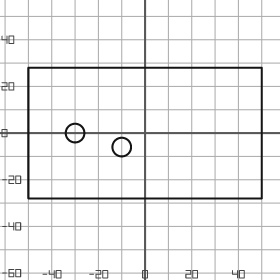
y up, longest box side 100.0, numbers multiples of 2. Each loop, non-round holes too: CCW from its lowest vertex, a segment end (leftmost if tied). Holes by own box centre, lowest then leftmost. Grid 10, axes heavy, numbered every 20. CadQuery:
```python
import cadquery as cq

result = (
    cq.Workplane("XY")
    .moveTo(-50.0, -28.0)
    .lineTo(50.0, -28.0)
    .lineTo(50.0, 28.0)
    .lineTo(-50.0, 28.0)
    .close()
    .moveTo(-10.0, -6.0)
    .circle(4.0)
    .moveTo(-30.0, 0.0)
    .circle(4.0)
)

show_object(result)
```